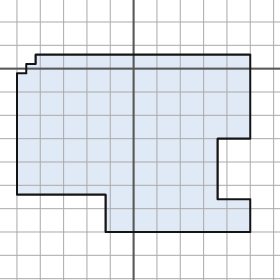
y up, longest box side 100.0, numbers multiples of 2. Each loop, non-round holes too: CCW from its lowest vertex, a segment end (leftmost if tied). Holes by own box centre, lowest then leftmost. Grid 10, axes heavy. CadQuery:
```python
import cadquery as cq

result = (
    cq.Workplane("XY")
    .moveTo(-12.0, -70.0)
    .lineTo(50.0, -70.0)
    .lineTo(50.0, -56.0)
    .lineTo(36.0, -56.0)
    .lineTo(36.0, -30.0)
    .lineTo(50.0, -30.0)
    .lineTo(50.0, 6.0)
    .lineTo(-42.0, 6.0)
    .lineTo(-42.0, 2.0)
    .lineTo(-46.0, 2.0)
    .lineTo(-46.0, -2.0)
    .lineTo(-50.0, -2.0)
    .lineTo(-50.0, -54.0)
    .lineTo(-12.0, -54.0)
    .close()
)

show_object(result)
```